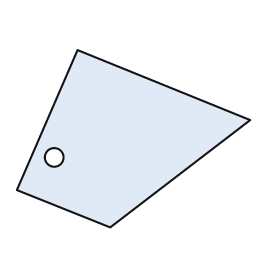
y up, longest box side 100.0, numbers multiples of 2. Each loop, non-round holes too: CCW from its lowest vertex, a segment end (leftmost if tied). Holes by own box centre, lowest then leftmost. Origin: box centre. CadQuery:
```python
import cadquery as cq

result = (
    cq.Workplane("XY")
    .moveTo(-10.0, -38.0)
    .lineTo(50.0, 8.0)
    .lineTo(-24.0, 38.0)
    .lineTo(-50.0, -22.0)
    .close()
    .moveTo(-34.0, -8.0)
    .circle(4.0)
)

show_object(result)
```